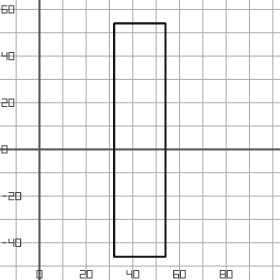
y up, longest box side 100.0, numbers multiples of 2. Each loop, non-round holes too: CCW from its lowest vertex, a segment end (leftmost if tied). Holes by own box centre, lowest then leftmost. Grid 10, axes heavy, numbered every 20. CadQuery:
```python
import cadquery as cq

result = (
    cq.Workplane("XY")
    .moveTo(32.0, -46.0)
    .lineTo(54.0, -46.0)
    .lineTo(54.0, 54.0)
    .lineTo(32.0, 54.0)
    .close()
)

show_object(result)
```